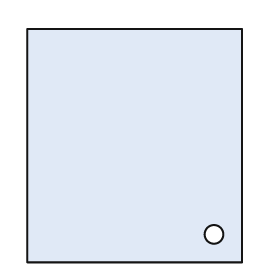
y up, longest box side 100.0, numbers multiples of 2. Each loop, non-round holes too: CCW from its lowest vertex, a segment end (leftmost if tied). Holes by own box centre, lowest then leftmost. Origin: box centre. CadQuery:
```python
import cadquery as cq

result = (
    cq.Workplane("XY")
    .moveTo(-46.0, -50.0)
    .lineTo(46.0, -50.0)
    .lineTo(46.0, 50.0)
    .lineTo(-46.0, 50.0)
    .close()
    .moveTo(34.0, -38.0)
    .circle(4.0)
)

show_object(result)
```